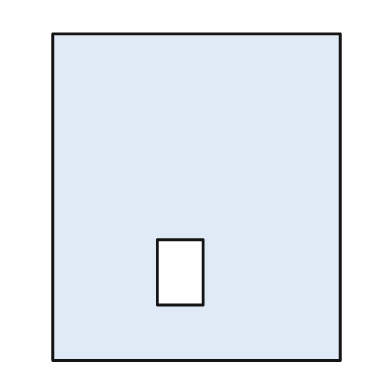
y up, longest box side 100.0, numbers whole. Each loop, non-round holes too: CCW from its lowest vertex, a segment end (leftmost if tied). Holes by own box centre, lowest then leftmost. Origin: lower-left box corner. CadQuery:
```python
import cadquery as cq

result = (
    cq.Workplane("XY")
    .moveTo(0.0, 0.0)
    .lineTo(88.0, 0.0)
    .lineTo(88.0, 100.0)
    .lineTo(0.0, 100.0)
    .close()
    .moveTo(32.0, 17.0)
    .lineTo(46.0, 17.0)
    .lineTo(46.0, 37.0)
    .lineTo(32.0, 37.0)
    .close()
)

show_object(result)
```